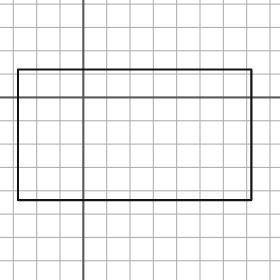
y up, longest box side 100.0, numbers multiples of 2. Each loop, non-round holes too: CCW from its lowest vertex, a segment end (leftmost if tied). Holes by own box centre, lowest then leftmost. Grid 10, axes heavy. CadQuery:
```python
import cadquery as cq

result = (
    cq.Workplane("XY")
    .moveTo(-28.0, -44.0)
    .lineTo(72.0, -44.0)
    .lineTo(72.0, 12.0)
    .lineTo(-28.0, 12.0)
    .close()
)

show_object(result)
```